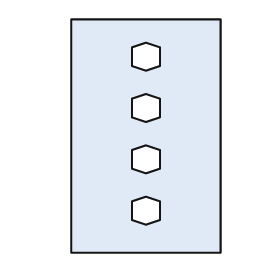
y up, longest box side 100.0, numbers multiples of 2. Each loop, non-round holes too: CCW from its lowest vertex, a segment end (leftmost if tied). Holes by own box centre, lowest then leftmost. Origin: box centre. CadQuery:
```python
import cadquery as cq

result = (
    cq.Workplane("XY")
    .moveTo(-32.0, -50.0)
    .lineTo(32.0, -50.0)
    .lineTo(32.0, 50.0)
    .lineTo(-32.0, 50.0)
    .close()
    .moveTo(0.0, -38.0)
    .lineTo(6.0, -36.0)
    .lineTo(6.0, -28.0)
    .lineTo(0.0, -26.0)
    .lineTo(-6.0, -28.0)
    .lineTo(-6.0, -36.0)
    .close()
    .moveTo(0.0, -16.0)
    .lineTo(6.0, -14.0)
    .lineTo(6.0, -6.0)
    .lineTo(0.0, -4.0)
    .lineTo(-6.0, -6.0)
    .lineTo(-6.0, -14.0)
    .close()
    .moveTo(0.0, 6.0)
    .lineTo(6.0, 8.0)
    .lineTo(6.0, 16.0)
    .lineTo(0.0, 18.0)
    .lineTo(-6.0, 16.0)
    .lineTo(-6.0, 8.0)
    .close()
    .moveTo(0.0, 28.0)
    .lineTo(6.0, 30.0)
    .lineTo(6.0, 38.0)
    .lineTo(0.0, 40.0)
    .lineTo(-6.0, 38.0)
    .lineTo(-6.0, 30.0)
    .close()
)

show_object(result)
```